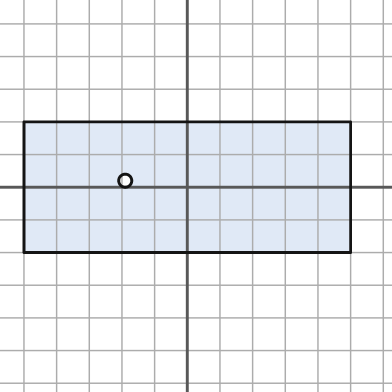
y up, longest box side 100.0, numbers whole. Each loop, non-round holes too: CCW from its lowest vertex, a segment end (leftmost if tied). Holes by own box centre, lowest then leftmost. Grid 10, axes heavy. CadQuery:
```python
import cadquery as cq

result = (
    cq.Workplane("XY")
    .moveTo(-50.0, -20.0)
    .lineTo(50.0, -20.0)
    .lineTo(50.0, 20.0)
    .lineTo(-50.0, 20.0)
    .close()
    .moveTo(-19.0, 2.0)
    .circle(2.0)
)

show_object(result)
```